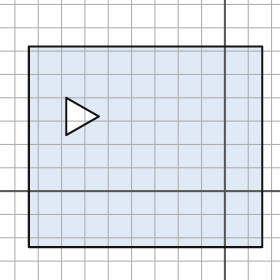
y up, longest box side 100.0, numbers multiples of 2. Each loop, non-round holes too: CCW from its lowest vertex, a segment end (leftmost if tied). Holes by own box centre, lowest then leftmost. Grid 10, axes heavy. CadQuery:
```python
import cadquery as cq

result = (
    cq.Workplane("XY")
    .moveTo(-84.0, -24.0)
    .lineTo(16.0, -24.0)
    .lineTo(16.0, 62.0)
    .lineTo(-84.0, 62.0)
    .close()
    .moveTo(-68.0, 24.0)
    .lineTo(-54.0, 32.0)
    .lineTo(-68.0, 40.0)
    .close()
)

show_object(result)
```